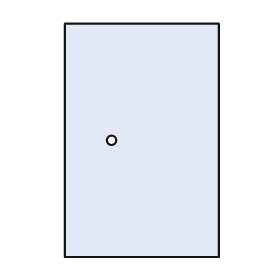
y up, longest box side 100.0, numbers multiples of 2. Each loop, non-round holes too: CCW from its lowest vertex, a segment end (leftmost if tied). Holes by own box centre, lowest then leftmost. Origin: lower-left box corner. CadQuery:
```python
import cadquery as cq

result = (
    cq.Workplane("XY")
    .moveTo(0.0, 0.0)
    .lineTo(66.0, 0.0)
    .lineTo(66.0, 100.0)
    .lineTo(0.0, 100.0)
    .close()
    .moveTo(20.0, 50.0)
    .circle(2.0)
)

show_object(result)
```